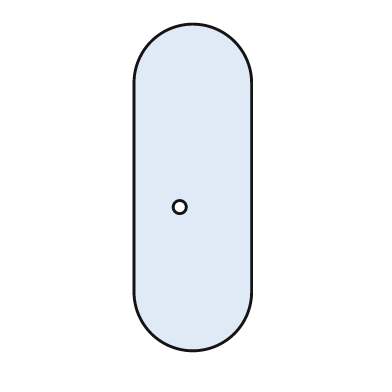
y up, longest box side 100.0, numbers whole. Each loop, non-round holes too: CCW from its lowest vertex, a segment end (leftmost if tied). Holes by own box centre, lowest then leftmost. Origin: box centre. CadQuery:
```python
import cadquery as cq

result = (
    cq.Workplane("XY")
    .moveTo(-18.0, -32.0)
    .threePointArc((0.0, -50.0), (18.0, -32.0))
    .lineTo(18.0, 32.0)
    .threePointArc((0.0, 50.0), (-18.0, 32.0))
    .close()
    .moveTo(-4.0, -6.0)
    .circle(2.0)
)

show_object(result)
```